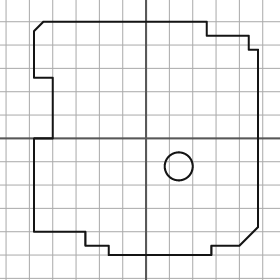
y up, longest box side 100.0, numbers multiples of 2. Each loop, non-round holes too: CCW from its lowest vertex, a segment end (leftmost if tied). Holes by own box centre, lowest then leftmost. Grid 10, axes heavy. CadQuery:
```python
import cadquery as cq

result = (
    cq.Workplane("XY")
    .moveTo(-16.0, -50.0)
    .lineTo(28.0, -50.0)
    .lineTo(28.0, -46.0)
    .lineTo(40.0, -46.0)
    .lineTo(48.0, -38.0)
    .lineTo(48.0, 38.0)
    .lineTo(44.0, 38.0)
    .lineTo(44.0, 44.0)
    .lineTo(26.0, 44.0)
    .lineTo(26.0, 50.0)
    .lineTo(-44.0, 50.0)
    .lineTo(-48.0, 46.0)
    .lineTo(-48.0, 26.0)
    .lineTo(-40.0, 26.0)
    .lineTo(-40.0, 0.0)
    .lineTo(-48.0, 0.0)
    .lineTo(-48.0, -40.0)
    .lineTo(-26.0, -40.0)
    .lineTo(-26.0, -46.0)
    .lineTo(-16.0, -46.0)
    .close()
    .moveTo(14.0, -12.0)
    .circle(6.0)
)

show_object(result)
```